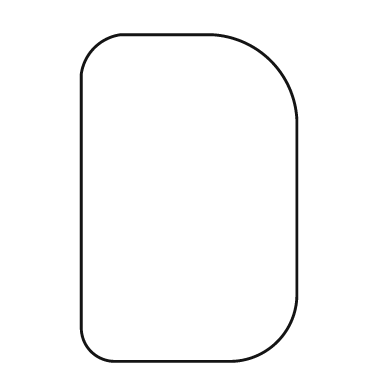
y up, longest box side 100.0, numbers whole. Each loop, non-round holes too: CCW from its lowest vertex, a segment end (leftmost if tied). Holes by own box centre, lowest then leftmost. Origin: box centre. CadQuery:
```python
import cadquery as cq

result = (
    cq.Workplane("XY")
    .moveTo(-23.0, -50.0)
    .lineTo(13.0, -50.0)
    .threePointArc((27.0, -44.0), (33.0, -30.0))
    .lineTo(33.0, 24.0)
    .threePointArc((25.0, 42.0), (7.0, 50.0))
    .lineTo(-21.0, 50.0)
    .threePointArc((-29.0, 46.0), (-33.0, 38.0))
    .lineTo(-33.0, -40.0)
    .threePointArc((-30.0, -47.0), (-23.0, -50.0))
    .close()
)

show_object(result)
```